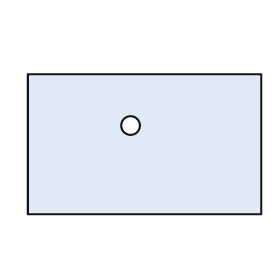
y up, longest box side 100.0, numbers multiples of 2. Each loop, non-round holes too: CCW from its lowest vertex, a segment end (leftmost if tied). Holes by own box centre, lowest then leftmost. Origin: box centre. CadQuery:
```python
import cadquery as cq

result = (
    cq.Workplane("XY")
    .moveTo(-50.0, -30.0)
    .lineTo(50.0, -30.0)
    .lineTo(50.0, 30.0)
    .lineTo(-50.0, 30.0)
    .close()
    .moveTo(-6.0, 8.0)
    .circle(4.0)
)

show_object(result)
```